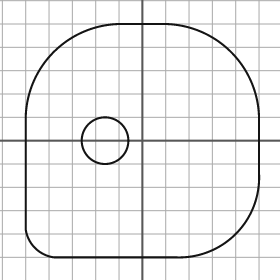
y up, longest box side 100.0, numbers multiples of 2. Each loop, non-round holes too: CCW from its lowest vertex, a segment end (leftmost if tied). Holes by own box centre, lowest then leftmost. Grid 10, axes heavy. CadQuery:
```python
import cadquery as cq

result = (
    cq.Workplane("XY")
    .moveTo(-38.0, -50.0)
    .lineTo(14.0, -50.0)
    .threePointArc((40.0, -40.0), (50.0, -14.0))
    .lineTo(50.0, 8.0)
    .threePointArc((38.0, 38.0), (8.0, 50.0))
    .lineTo(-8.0, 50.0)
    .threePointArc((-38.0, 38.0), (-50.0, 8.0))
    .lineTo(-50.0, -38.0)
    .threePointArc((-46.0, -46.0), (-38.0, -50.0))
    .close()
    .moveTo(-16.0, 0.0)
    .circle(10.0)
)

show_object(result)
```